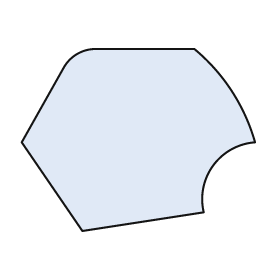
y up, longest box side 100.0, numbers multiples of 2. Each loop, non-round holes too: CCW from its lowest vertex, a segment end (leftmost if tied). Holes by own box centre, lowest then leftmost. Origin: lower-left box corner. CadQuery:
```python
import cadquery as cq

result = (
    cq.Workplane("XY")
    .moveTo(26.0, 0.0)
    .lineTo(78.0, 8.0)
    .threePointArc((82.0, 28.0), (100.0, 38.0))
    .threePointArc((90.0, 60.0), (74.0, 78.0))
    .lineTo(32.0, 78.0)
    .threePointArc((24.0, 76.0), (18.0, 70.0))
    .lineTo(0.0, 38.0)
    .close()
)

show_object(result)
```